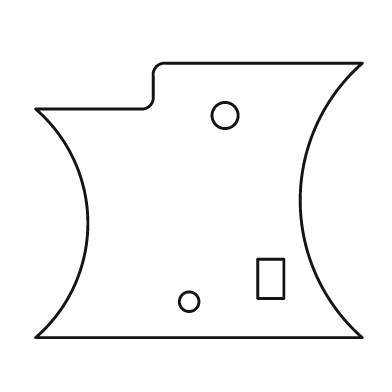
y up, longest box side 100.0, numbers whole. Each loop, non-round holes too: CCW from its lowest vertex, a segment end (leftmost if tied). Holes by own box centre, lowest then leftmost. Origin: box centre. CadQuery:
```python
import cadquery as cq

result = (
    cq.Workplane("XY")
    .moveTo(-50.0, -42.0)
    .lineTo(50.0, -42.0)
    .threePointArc((31.0, 0.0), (50.0, 42.0))
    .lineTo(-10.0, 42.0)
    .threePointArc((-13.0, 41.0), (-14.0, 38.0))
    .lineTo(-14.0, 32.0)
    .threePointArc((-15.0, 29.0), (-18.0, 28.0))
    .lineTo(-50.0, 28.0)
    .threePointArc((-34.0, -7.0), (-50.0, -42.0))
    .close()
    .moveTo(-3.0, -31.0)
    .circle(3.0)
    .moveTo(18.0, -30.0)
    .lineTo(26.0, -30.0)
    .lineTo(26.0, -18.0)
    .lineTo(18.0, -18.0)
    .close()
    .moveTo(8.0, 26.0)
    .circle(4.0)
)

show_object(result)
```